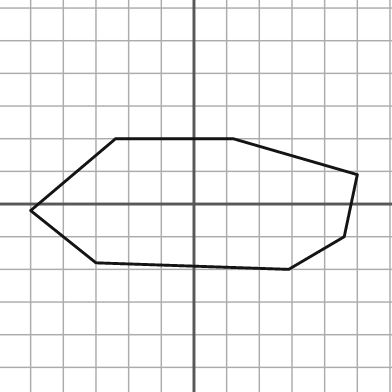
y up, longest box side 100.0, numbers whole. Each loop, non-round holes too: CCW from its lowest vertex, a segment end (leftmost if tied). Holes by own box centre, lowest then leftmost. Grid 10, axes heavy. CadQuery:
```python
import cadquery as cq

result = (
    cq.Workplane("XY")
    .moveTo(29.0, -20.0)
    .lineTo(46.0, -10.0)
    .lineTo(50.0, 9.0)
    .lineTo(12.0, 20.0)
    .lineTo(-24.0, 20.0)
    .lineTo(-50.0, -2.0)
    .lineTo(-30.0, -18.0)
    .close()
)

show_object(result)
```